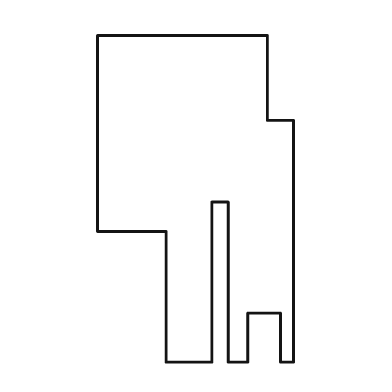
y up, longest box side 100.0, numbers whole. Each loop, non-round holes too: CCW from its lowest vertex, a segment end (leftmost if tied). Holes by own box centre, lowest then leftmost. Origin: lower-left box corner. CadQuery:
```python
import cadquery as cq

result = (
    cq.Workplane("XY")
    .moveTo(21.0, 0.0)
    .lineTo(35.0, 0.0)
    .lineTo(35.0, 49.0)
    .lineTo(40.0, 49.0)
    .lineTo(40.0, 0.0)
    .lineTo(46.0, 0.0)
    .lineTo(46.0, 15.0)
    .lineTo(56.0, 15.0)
    .lineTo(56.0, 0.0)
    .lineTo(60.0, 0.0)
    .lineTo(60.0, 74.0)
    .lineTo(52.0, 74.0)
    .lineTo(52.0, 100.0)
    .lineTo(0.0, 100.0)
    .lineTo(0.0, 40.0)
    .lineTo(21.0, 40.0)
    .close()
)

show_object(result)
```